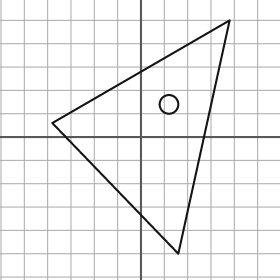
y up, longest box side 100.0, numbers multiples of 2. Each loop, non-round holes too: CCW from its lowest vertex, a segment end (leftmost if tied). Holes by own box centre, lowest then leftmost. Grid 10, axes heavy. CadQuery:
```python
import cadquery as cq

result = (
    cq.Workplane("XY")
    .moveTo(16.0, -50.0)
    .lineTo(38.0, 50.0)
    .lineTo(-38.0, 6.0)
    .close()
    .moveTo(12.0, 14.0)
    .circle(4.0)
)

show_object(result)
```